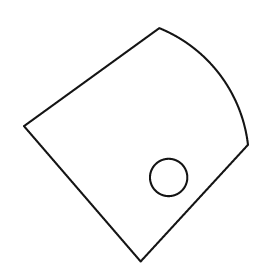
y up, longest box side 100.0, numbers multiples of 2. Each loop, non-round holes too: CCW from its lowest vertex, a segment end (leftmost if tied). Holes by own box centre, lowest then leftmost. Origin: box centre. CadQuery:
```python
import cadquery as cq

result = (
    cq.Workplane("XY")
    .moveTo(2.0, -50.0)
    .lineTo(48.0, 0.0)
    .threePointArc((36.0, 30.0), (10.0, 50.0))
    .lineTo(-48.0, 8.0)
    .close()
    .moveTo(14.0, -14.0)
    .circle(8.0)
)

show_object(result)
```